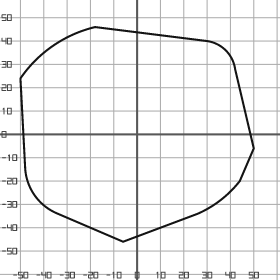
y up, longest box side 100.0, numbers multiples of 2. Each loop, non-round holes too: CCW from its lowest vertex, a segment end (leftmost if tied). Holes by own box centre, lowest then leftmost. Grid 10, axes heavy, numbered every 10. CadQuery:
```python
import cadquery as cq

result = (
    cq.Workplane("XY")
    .moveTo(-6.0, -46.0)
    .lineTo(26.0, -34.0)
    .threePointArc((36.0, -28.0), (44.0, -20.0))
    .lineTo(50.0, -6.0)
    .lineTo(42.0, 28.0)
    .threePointArc((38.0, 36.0), (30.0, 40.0))
    .lineTo(-18.0, 46.0)
    .threePointArc((-36.0, 38.0), (-50.0, 24.0))
    .lineTo(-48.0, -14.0)
    .threePointArc((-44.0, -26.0), (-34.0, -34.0))
    .close()
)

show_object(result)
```